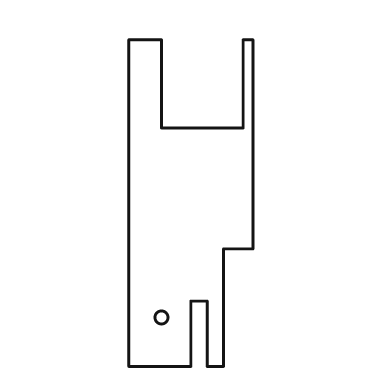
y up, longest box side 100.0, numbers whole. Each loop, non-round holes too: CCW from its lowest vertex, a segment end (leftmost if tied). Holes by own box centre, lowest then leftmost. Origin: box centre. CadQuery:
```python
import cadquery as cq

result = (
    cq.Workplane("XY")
    .moveTo(-19.0, -50.0)
    .lineTo(0.0, -50.0)
    .lineTo(0.0, -30.0)
    .lineTo(5.0, -30.0)
    .lineTo(5.0, -50.0)
    .lineTo(10.0, -50.0)
    .lineTo(10.0, -14.0)
    .lineTo(19.0, -14.0)
    .lineTo(19.0, 50.0)
    .lineTo(16.0, 50.0)
    .lineTo(16.0, 23.0)
    .lineTo(-9.0, 23.0)
    .lineTo(-9.0, 50.0)
    .lineTo(-19.0, 50.0)
    .close()
    .moveTo(-9.0, -35.0)
    .circle(2.0)
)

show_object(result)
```